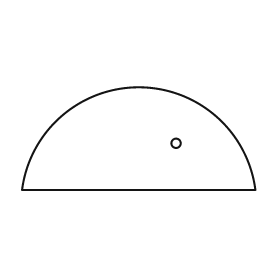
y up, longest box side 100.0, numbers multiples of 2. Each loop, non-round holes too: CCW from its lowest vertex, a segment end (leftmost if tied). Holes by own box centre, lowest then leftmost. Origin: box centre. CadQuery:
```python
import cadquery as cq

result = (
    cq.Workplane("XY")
    .moveTo(-50.0, -22.0)
    .lineTo(50.0, -22.0)
    .threePointArc((0.0, 22.0), (-50.0, -22.0))
    .close()
    .moveTo(16.0, -2.0)
    .circle(2.0)
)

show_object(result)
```